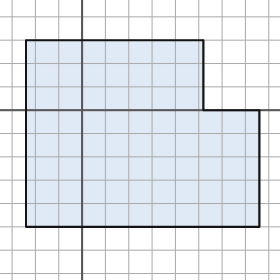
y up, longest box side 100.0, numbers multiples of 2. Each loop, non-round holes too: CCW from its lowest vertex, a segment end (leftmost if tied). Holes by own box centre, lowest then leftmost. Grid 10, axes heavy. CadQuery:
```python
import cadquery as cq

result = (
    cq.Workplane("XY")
    .moveTo(-24.0, -50.0)
    .lineTo(76.0, -50.0)
    .lineTo(76.0, 0.0)
    .lineTo(52.0, 0.0)
    .lineTo(52.0, 30.0)
    .lineTo(-24.0, 30.0)
    .close()
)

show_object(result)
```